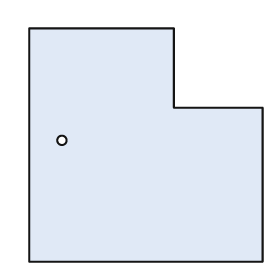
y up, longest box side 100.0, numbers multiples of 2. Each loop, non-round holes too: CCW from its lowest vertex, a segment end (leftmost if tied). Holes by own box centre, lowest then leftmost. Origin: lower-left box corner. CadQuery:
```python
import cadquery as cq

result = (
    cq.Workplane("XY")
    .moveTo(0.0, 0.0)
    .lineTo(100.0, 0.0)
    .lineTo(100.0, 66.0)
    .lineTo(62.0, 66.0)
    .lineTo(62.0, 100.0)
    .lineTo(0.0, 100.0)
    .close()
    .moveTo(14.0, 52.0)
    .circle(2.0)
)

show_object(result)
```